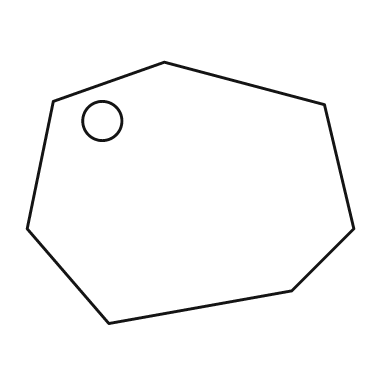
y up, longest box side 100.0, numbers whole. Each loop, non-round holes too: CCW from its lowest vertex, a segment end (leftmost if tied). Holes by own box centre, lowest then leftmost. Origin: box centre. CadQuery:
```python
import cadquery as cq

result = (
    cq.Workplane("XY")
    .moveTo(-25.0, -40.0)
    .lineTo(31.0, -30.0)
    .lineTo(50.0, -11.0)
    .lineTo(41.0, 27.0)
    .lineTo(-8.0, 40.0)
    .lineTo(-42.0, 28.0)
    .lineTo(-50.0, -11.0)
    .close()
    .moveTo(-27.0, 22.0)
    .circle(6.0)
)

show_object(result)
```